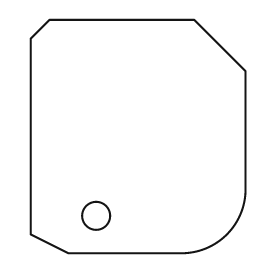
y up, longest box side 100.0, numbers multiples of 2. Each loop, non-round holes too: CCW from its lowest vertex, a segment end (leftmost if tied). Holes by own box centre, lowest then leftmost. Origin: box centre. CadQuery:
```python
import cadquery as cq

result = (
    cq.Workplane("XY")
    .moveTo(-30.0, -50.0)
    .lineTo(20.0, -50.0)
    .threePointArc((38.0, -42.0), (46.0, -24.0))
    .lineTo(46.0, 28.0)
    .lineTo(24.0, 50.0)
    .lineTo(-38.0, 50.0)
    .lineTo(-46.0, 42.0)
    .lineTo(-46.0, -42.0)
    .close()
    .moveTo(-18.0, -34.0)
    .circle(6.0)
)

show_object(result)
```